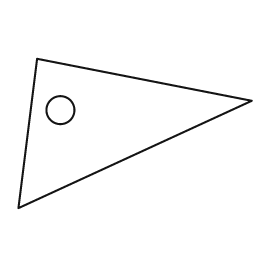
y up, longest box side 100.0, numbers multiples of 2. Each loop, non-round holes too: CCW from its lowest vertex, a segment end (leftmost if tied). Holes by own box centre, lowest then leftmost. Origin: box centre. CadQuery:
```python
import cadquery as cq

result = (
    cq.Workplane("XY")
    .moveTo(-50.0, -32.0)
    .lineTo(50.0, 14.0)
    .lineTo(-42.0, 32.0)
    .close()
    .moveTo(-32.0, 10.0)
    .circle(6.0)
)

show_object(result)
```